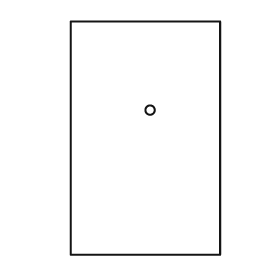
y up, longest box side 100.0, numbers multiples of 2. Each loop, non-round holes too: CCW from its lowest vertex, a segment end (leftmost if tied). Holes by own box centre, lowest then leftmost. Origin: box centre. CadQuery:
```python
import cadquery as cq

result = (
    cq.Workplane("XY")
    .moveTo(-32.0, -50.0)
    .lineTo(32.0, -50.0)
    .lineTo(32.0, 50.0)
    .lineTo(-32.0, 50.0)
    .close()
    .moveTo(2.0, 12.0)
    .circle(2.0)
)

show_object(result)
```